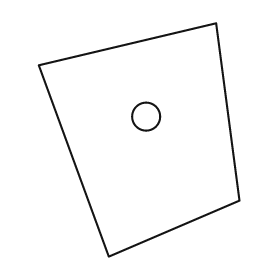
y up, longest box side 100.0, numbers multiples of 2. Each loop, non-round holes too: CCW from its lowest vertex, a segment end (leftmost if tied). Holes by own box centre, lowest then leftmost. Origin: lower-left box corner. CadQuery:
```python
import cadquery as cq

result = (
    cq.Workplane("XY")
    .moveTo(30.0, 0.0)
    .lineTo(86.0, 24.0)
    .lineTo(76.0, 100.0)
    .lineTo(0.0, 82.0)
    .close()
    .moveTo(46.0, 60.0)
    .circle(6.0)
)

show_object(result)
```